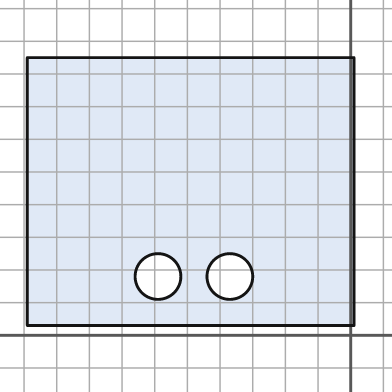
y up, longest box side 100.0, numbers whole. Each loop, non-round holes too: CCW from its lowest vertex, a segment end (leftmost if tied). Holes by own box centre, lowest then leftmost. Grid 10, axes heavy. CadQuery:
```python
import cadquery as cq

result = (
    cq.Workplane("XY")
    .moveTo(-99.0, 3.0)
    .lineTo(1.0, 3.0)
    .lineTo(1.0, 85.0)
    .lineTo(-99.0, 85.0)
    .close()
    .moveTo(-59.0, 18.0)
    .circle(7.0)
    .moveTo(-37.0, 18.0)
    .circle(7.0)
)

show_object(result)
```